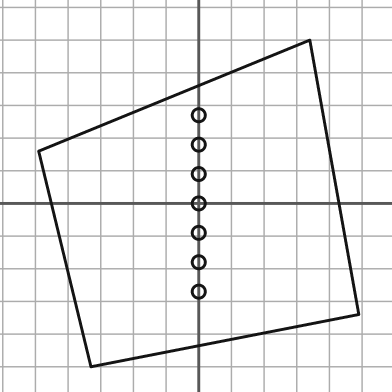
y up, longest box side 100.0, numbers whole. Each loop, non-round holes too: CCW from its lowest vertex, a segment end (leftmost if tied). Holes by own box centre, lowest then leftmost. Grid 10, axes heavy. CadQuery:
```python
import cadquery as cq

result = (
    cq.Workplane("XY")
    .moveTo(-33.0, -50.0)
    .lineTo(49.0, -34.0)
    .lineTo(34.0, 50.0)
    .lineTo(-49.0, 16.0)
    .close()
    .moveTo(0.0, -27.0)
    .circle(2.0)
    .moveTo(0.0, -18.0)
    .circle(2.0)
    .moveTo(0.0, -9.0)
    .circle(2.0)
    .moveTo(0.0, 0.0)
    .circle(2.0)
    .moveTo(0.0, 9.0)
    .circle(2.0)
    .moveTo(0.0, 18.0)
    .circle(2.0)
    .moveTo(0.0, 27.0)
    .circle(2.0)
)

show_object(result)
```